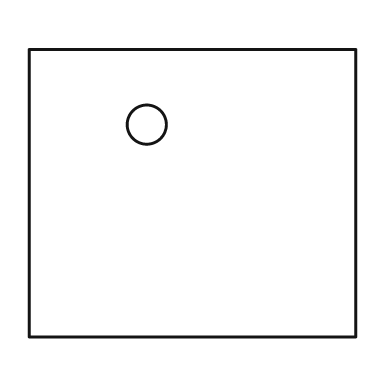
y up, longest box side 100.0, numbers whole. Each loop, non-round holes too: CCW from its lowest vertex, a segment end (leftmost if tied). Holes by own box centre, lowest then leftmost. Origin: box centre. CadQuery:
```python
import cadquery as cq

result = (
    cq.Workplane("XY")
    .moveTo(-50.0, -44.0)
    .lineTo(50.0, -44.0)
    .lineTo(50.0, 44.0)
    .lineTo(-50.0, 44.0)
    .close()
    .moveTo(-14.0, 21.0)
    .circle(6.0)
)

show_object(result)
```